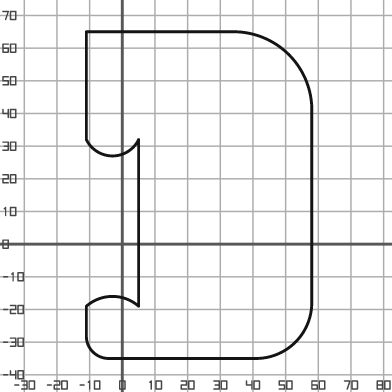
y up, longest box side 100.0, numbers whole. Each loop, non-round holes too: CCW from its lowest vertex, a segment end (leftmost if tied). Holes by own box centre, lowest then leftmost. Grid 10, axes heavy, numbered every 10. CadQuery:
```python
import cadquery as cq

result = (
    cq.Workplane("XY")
    .moveTo(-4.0, -35.0)
    .lineTo(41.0, -35.0)
    .threePointArc((53.0, -30.0), (58.0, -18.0))
    .lineTo(58.0, 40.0)
    .threePointArc((51.0, 58.0), (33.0, 65.0))
    .lineTo(-11.0, 65.0)
    .lineTo(-11.0, 32.0)
    .threePointArc((-3.0, 27.0), (5.0, 32.0))
    .lineTo(5.0, -19.0)
    .threePointArc((-3.0, -16.0), (-11.0, -19.0))
    .lineTo(-11.0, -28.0)
    .threePointArc((-9.0, -33.0), (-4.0, -35.0))
    .close()
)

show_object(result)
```